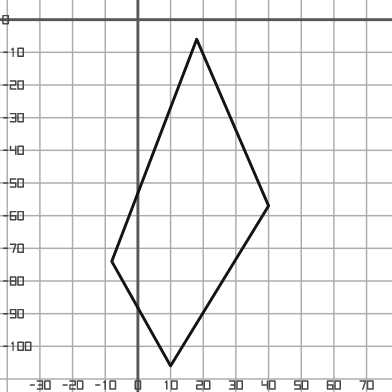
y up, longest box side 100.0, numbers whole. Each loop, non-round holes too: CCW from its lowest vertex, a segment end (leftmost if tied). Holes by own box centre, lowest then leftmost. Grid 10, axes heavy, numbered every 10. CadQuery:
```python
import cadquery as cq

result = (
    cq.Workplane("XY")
    .moveTo(10.0, -106.0)
    .lineTo(40.0, -57.0)
    .lineTo(18.0, -6.0)
    .lineTo(-8.0, -74.0)
    .close()
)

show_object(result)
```